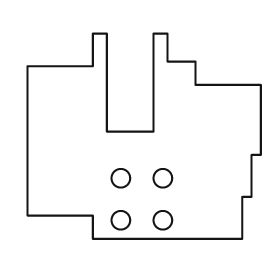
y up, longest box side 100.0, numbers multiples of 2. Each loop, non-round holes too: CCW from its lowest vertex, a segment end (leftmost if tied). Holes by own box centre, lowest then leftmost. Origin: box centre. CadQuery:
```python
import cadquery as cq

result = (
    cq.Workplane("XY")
    .moveTo(-22.0, -44.0)
    .lineTo(42.0, -44.0)
    .lineTo(42.0, -26.0)
    .lineTo(46.0, -26.0)
    .lineTo(46.0, -8.0)
    .lineTo(50.0, -8.0)
    .lineTo(50.0, 22.0)
    .lineTo(22.0, 22.0)
    .lineTo(22.0, 32.0)
    .lineTo(10.0, 32.0)
    .lineTo(10.0, 44.0)
    .lineTo(4.0, 44.0)
    .lineTo(4.0, 2.0)
    .lineTo(-16.0, 2.0)
    .lineTo(-16.0, 44.0)
    .lineTo(-22.0, 44.0)
    .lineTo(-22.0, 30.0)
    .lineTo(-50.0, 30.0)
    .lineTo(-50.0, -34.0)
    .lineTo(-22.0, -34.0)
    .close()
    .moveTo(-10.0, -36.0)
    .circle(4.0)
    .moveTo(8.0, -36.0)
    .circle(4.0)
    .moveTo(-10.0, -18.0)
    .circle(4.0)
    .moveTo(8.0, -18.0)
    .circle(4.0)
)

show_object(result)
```